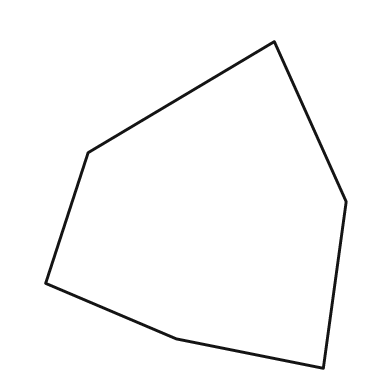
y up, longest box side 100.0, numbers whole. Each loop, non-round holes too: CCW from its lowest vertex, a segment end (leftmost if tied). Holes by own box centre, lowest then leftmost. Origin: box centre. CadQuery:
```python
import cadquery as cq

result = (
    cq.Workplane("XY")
    .moveTo(39.0, -50.0)
    .lineTo(46.0, 1.0)
    .lineTo(24.0, 50.0)
    .lineTo(-33.0, 16.0)
    .lineTo(-46.0, -24.0)
    .lineTo(-6.0, -41.0)
    .close()
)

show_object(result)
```